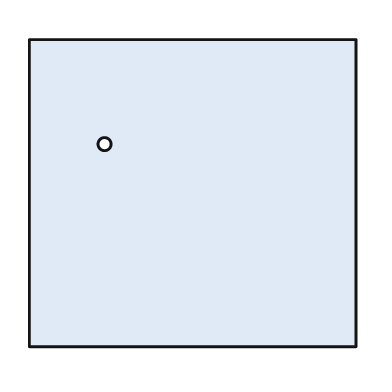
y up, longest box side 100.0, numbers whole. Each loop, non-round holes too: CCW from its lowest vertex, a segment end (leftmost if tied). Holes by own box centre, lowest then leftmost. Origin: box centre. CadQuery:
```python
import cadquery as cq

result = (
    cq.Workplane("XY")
    .moveTo(-50.0, -47.0)
    .lineTo(50.0, -47.0)
    .lineTo(50.0, 47.0)
    .lineTo(-50.0, 47.0)
    .close()
    .moveTo(-27.0, 15.0)
    .circle(2.0)
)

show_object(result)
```